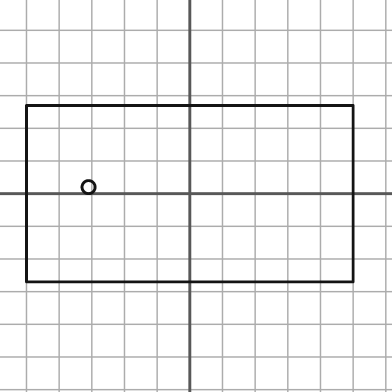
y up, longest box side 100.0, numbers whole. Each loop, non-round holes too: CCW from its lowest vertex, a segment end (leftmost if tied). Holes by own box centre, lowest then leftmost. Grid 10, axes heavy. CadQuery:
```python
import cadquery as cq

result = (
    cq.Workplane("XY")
    .moveTo(-50.0, -27.0)
    .lineTo(50.0, -27.0)
    .lineTo(50.0, 27.0)
    .lineTo(-50.0, 27.0)
    .close()
    .moveTo(-31.0, 2.0)
    .circle(2.0)
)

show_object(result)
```